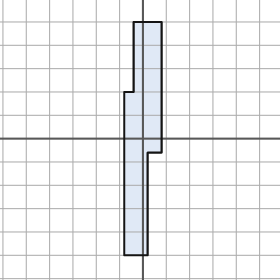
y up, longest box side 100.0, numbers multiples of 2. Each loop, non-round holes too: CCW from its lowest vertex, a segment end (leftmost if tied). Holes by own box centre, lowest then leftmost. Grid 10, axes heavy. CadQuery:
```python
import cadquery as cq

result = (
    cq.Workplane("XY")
    .moveTo(-8.0, -50.0)
    .lineTo(2.0, -50.0)
    .lineTo(2.0, -6.0)
    .lineTo(8.0, -6.0)
    .lineTo(8.0, 50.0)
    .lineTo(-4.0, 50.0)
    .lineTo(-4.0, 20.0)
    .lineTo(-8.0, 20.0)
    .close()
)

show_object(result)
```